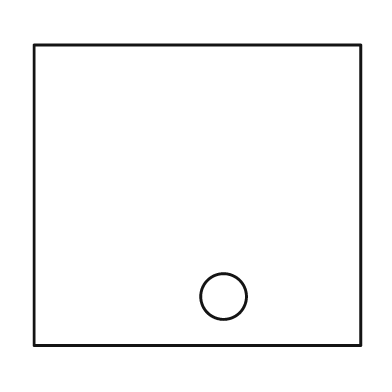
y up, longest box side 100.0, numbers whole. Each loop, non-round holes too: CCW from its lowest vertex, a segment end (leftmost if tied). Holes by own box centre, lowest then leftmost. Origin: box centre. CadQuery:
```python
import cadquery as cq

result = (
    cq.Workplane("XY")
    .moveTo(-50.0, -46.0)
    .lineTo(50.0, -46.0)
    .lineTo(50.0, 46.0)
    .lineTo(-50.0, 46.0)
    .close()
    .moveTo(8.0, -31.0)
    .circle(7.0)
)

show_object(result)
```